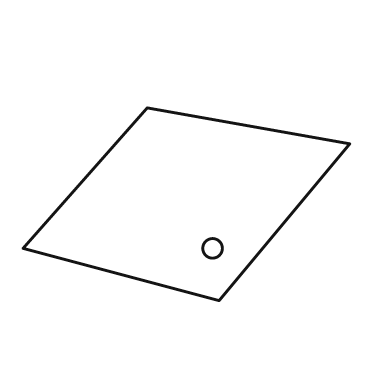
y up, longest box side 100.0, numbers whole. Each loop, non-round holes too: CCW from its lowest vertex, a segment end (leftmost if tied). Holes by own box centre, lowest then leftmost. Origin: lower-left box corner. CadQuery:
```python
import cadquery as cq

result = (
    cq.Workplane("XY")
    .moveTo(60.0, 0.0)
    .lineTo(100.0, 48.0)
    .lineTo(38.0, 59.0)
    .lineTo(0.0, 16.0)
    .close()
    .moveTo(58.0, 16.0)
    .circle(3.0)
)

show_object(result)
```